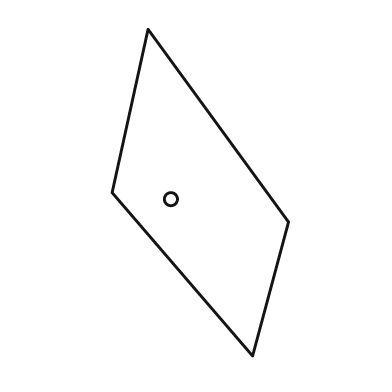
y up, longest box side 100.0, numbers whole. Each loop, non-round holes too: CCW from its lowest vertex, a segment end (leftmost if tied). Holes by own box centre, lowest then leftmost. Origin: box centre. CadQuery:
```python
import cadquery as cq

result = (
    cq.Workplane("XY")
    .moveTo(16.0, -50.0)
    .lineTo(27.0, -9.0)
    .lineTo(-16.0, 50.0)
    .lineTo(-27.0, 0.0)
    .close()
    .moveTo(-9.0, -2.0)
    .circle(2.0)
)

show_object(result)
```